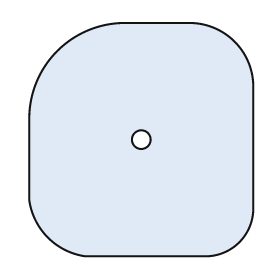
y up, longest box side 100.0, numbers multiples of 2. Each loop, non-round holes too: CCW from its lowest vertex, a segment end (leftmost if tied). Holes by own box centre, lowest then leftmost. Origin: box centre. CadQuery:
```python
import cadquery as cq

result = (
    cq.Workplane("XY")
    .moveTo(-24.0, -50.0)
    .lineTo(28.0, -50.0)
    .threePointArc((42.0, -44.0), (48.0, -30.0))
    .lineTo(48.0, 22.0)
    .threePointArc((40.0, 42.0), (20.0, 50.0))
    .lineTo(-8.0, 50.0)
    .threePointArc((-36.0, 38.0), (-48.0, 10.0))
    .lineTo(-48.0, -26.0)
    .threePointArc((-40.0, -42.0), (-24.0, -50.0))
    .close()
    .moveTo(0.0, 0.0)
    .circle(4.0)
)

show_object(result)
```